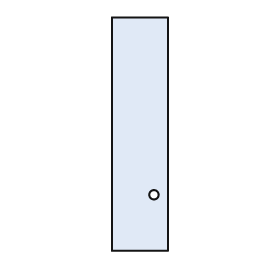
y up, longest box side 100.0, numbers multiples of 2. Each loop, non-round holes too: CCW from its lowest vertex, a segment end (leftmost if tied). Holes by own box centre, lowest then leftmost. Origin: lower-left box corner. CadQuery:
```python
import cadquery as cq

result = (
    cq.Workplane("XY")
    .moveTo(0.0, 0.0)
    .lineTo(24.0, 0.0)
    .lineTo(24.0, 100.0)
    .lineTo(0.0, 100.0)
    .close()
    .moveTo(18.0, 24.0)
    .circle(2.0)
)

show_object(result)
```